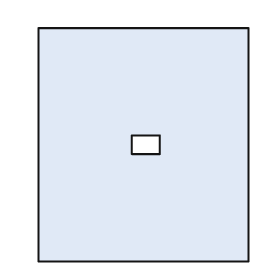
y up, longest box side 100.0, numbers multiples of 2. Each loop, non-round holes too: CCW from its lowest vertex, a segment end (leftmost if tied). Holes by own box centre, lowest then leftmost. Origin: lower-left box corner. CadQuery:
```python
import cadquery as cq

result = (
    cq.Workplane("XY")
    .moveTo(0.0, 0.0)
    .lineTo(90.0, 0.0)
    .lineTo(90.0, 100.0)
    .lineTo(0.0, 100.0)
    .close()
    .moveTo(40.0, 46.0)
    .lineTo(52.0, 46.0)
    .lineTo(52.0, 54.0)
    .lineTo(40.0, 54.0)
    .close()
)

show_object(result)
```